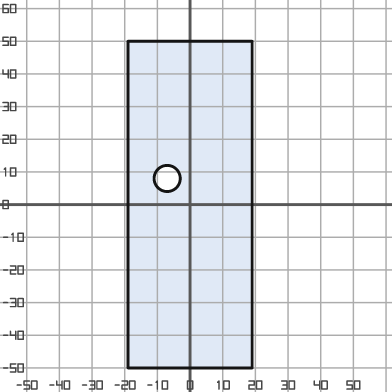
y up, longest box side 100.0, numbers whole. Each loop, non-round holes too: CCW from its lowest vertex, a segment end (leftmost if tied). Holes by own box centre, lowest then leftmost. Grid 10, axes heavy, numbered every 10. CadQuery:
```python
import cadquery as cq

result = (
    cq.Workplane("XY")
    .moveTo(-19.0, -50.0)
    .lineTo(19.0, -50.0)
    .lineTo(19.0, 50.0)
    .lineTo(-19.0, 50.0)
    .close()
    .moveTo(-7.0, 8.0)
    .circle(4.0)
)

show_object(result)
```